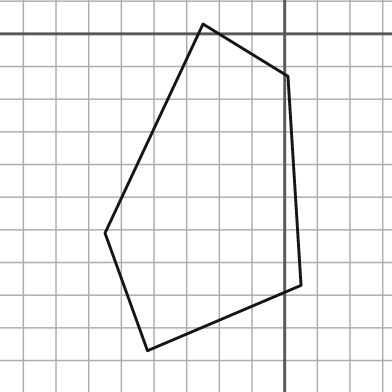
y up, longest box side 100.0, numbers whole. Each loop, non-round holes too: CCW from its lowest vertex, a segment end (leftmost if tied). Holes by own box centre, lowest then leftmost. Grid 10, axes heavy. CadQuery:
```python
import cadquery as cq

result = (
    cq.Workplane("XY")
    .moveTo(-42.0, -97.0)
    .lineTo(5.0, -77.0)
    .lineTo(1.0, -13.0)
    .lineTo(-25.0, 3.0)
    .lineTo(-55.0, -61.0)
    .close()
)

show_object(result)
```